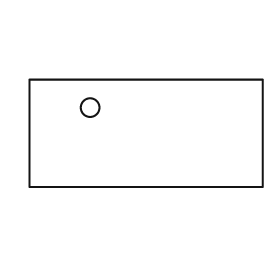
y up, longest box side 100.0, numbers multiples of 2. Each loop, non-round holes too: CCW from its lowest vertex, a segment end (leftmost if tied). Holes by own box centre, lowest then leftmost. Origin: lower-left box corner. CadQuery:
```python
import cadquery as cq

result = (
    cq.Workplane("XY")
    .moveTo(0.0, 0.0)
    .lineTo(100.0, 0.0)
    .lineTo(100.0, 46.0)
    .lineTo(0.0, 46.0)
    .close()
    .moveTo(26.0, 34.0)
    .circle(4.0)
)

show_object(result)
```